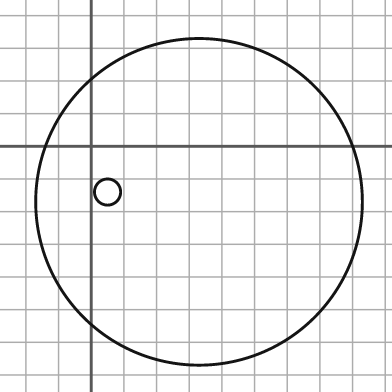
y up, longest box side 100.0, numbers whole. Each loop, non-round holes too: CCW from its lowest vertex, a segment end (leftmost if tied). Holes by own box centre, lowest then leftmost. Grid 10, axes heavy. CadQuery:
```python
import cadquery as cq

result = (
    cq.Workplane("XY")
    .moveTo(33.0, -17.0)
    .circle(50.0)
    .moveTo(5.0, -14.0)
    .circle(4.0)
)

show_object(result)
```